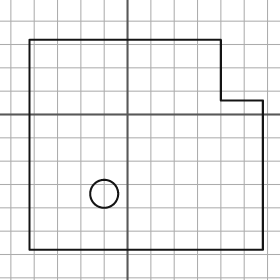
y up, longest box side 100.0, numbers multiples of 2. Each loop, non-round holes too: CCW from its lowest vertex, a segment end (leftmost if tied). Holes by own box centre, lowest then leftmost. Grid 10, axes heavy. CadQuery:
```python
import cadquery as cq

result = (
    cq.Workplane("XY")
    .moveTo(-42.0, -58.0)
    .lineTo(58.0, -58.0)
    .lineTo(58.0, 6.0)
    .lineTo(40.0, 6.0)
    .lineTo(40.0, 32.0)
    .lineTo(-42.0, 32.0)
    .close()
    .moveTo(-10.0, -34.0)
    .circle(6.0)
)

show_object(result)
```